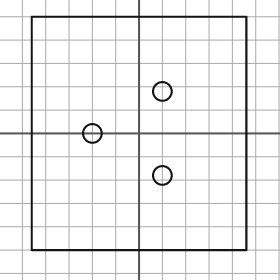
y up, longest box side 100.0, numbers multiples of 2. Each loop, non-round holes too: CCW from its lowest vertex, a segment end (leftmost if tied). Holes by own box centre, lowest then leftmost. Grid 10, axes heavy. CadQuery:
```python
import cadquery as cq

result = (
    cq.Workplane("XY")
    .moveTo(-46.0, -50.0)
    .lineTo(46.0, -50.0)
    .lineTo(46.0, 50.0)
    .lineTo(-46.0, 50.0)
    .close()
    .moveTo(10.0, -18.0)
    .circle(4.0)
    .moveTo(-20.0, 0.0)
    .circle(4.0)
    .moveTo(10.0, 18.0)
    .circle(4.0)
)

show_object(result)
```